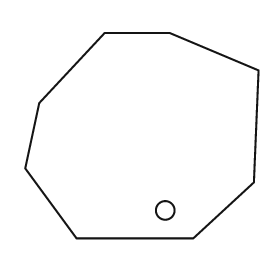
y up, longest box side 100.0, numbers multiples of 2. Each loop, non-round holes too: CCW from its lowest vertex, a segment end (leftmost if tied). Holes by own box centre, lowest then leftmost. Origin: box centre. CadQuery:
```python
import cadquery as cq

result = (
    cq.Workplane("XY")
    .moveTo(-28.0, -44.0)
    .lineTo(22.0, -44.0)
    .lineTo(48.0, -20.0)
    .lineTo(50.0, 28.0)
    .lineTo(12.0, 44.0)
    .lineTo(-16.0, 44.0)
    .lineTo(-44.0, 14.0)
    .lineTo(-50.0, -14.0)
    .close()
    .moveTo(10.0, -32.0)
    .circle(4.0)
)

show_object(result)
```